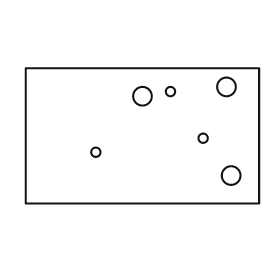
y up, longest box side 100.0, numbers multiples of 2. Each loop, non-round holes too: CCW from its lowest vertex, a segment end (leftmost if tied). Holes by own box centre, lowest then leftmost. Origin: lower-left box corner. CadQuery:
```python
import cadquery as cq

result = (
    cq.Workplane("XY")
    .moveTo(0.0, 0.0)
    .lineTo(100.0, 0.0)
    .lineTo(100.0, 58.0)
    .lineTo(0.0, 58.0)
    .close()
    .moveTo(88.0, 12.0)
    .circle(4.0)
    .moveTo(30.0, 22.0)
    .circle(2.0)
    .moveTo(76.0, 28.0)
    .circle(2.0)
    .moveTo(50.0, 46.0)
    .circle(4.0)
    .moveTo(62.0, 48.0)
    .circle(2.0)
    .moveTo(86.0, 50.0)
    .circle(4.0)
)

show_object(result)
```